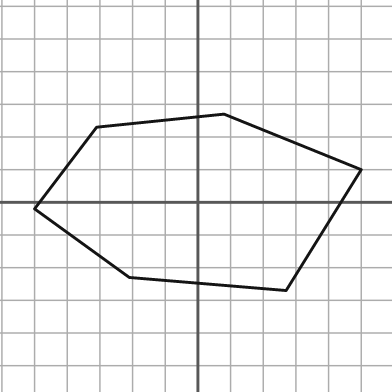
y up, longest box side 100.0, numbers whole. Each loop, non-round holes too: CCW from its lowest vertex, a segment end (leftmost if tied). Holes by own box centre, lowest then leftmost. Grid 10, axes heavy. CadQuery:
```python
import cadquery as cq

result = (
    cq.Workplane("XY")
    .moveTo(27.0, -27.0)
    .lineTo(50.0, 10.0)
    .lineTo(8.0, 27.0)
    .lineTo(-31.0, 23.0)
    .lineTo(-50.0, -2.0)
    .lineTo(-21.0, -23.0)
    .close()
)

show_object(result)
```